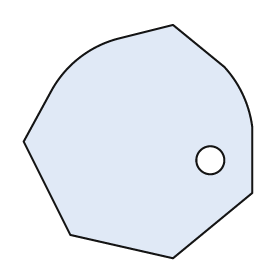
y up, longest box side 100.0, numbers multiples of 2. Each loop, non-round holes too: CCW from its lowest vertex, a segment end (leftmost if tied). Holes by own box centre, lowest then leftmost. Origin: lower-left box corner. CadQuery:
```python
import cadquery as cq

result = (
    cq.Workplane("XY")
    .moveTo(64.0, 0.0)
    .lineTo(98.0, 28.0)
    .lineTo(98.0, 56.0)
    .threePointArc((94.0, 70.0), (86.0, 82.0))
    .lineTo(64.0, 100.0)
    .lineTo(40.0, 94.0)
    .threePointArc((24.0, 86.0), (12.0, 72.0))
    .lineTo(0.0, 50.0)
    .lineTo(20.0, 10.0)
    .close()
    .moveTo(80.0, 42.0)
    .circle(6.0)
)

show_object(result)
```